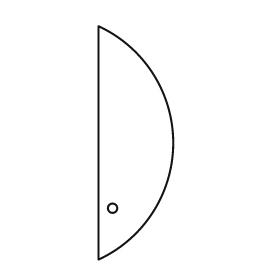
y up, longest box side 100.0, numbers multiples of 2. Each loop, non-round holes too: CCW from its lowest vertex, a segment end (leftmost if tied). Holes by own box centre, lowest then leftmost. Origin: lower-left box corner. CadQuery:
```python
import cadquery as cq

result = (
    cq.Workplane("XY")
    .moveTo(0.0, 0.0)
    .threePointArc((32.0, 50.0), (0.0, 100.0))
    .close()
    .moveTo(6.0, 22.0)
    .circle(2.0)
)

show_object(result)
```